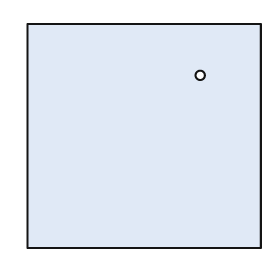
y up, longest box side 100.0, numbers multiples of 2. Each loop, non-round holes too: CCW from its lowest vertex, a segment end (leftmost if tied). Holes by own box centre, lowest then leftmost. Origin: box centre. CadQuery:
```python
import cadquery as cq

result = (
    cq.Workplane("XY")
    .moveTo(-50.0, -48.0)
    .lineTo(50.0, -48.0)
    .lineTo(50.0, 48.0)
    .lineTo(-50.0, 48.0)
    .close()
    .moveTo(24.0, 26.0)
    .circle(2.0)
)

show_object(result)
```